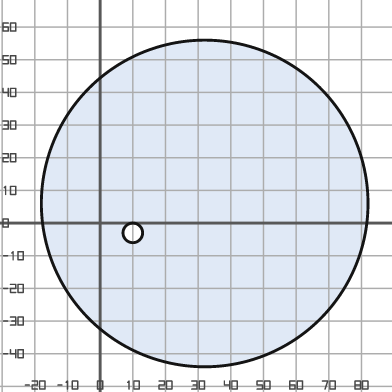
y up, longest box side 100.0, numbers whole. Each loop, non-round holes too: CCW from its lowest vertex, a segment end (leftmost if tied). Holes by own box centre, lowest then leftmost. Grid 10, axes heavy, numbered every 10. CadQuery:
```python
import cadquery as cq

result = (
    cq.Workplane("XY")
    .moveTo(32.0, 6.0)
    .circle(50.0)
    .moveTo(10.0, -3.0)
    .circle(3.0)
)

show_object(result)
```